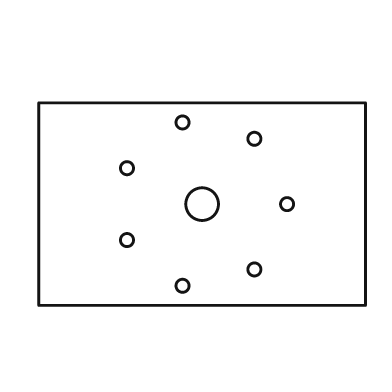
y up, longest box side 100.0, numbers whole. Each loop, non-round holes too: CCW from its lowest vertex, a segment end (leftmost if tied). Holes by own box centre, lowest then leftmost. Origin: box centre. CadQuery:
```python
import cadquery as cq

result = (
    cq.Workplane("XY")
    .moveTo(-50.0, -31.0)
    .lineTo(50.0, -31.0)
    .lineTo(50.0, 31.0)
    .lineTo(-50.0, 31.0)
    .close()
    .moveTo(-6.0, -25.0)
    .circle(2.0)
    .moveTo(16.0, -20.0)
    .circle(2.0)
    .moveTo(-23.0, -11.0)
    .circle(2.0)
    .moveTo(0.0, 0.0)
    .circle(5.0)
    .moveTo(26.0, 0.0)
    .circle(2.0)
    .moveTo(-23.0, 11.0)
    .circle(2.0)
    .moveTo(16.0, 20.0)
    .circle(2.0)
    .moveTo(-6.0, 25.0)
    .circle(2.0)
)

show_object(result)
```